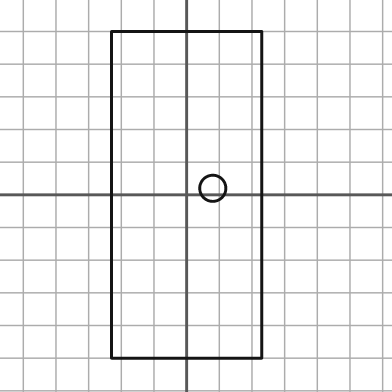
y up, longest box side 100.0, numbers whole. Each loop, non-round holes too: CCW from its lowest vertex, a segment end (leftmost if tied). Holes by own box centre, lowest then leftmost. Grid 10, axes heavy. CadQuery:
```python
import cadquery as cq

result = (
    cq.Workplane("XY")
    .moveTo(-23.0, -50.0)
    .lineTo(23.0, -50.0)
    .lineTo(23.0, 50.0)
    .lineTo(-23.0, 50.0)
    .close()
    .moveTo(8.0, 2.0)
    .circle(4.0)
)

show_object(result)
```